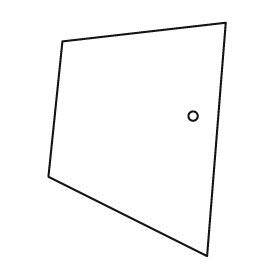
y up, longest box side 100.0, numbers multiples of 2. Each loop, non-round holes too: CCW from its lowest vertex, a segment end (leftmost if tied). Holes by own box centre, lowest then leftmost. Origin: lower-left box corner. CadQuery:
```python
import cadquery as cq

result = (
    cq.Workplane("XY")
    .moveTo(68.0, 0.0)
    .lineTo(76.0, 100.0)
    .lineTo(6.0, 92.0)
    .lineTo(0.0, 34.0)
    .close()
    .moveTo(62.0, 60.0)
    .circle(2.0)
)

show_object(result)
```